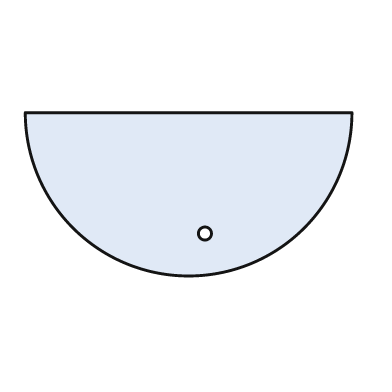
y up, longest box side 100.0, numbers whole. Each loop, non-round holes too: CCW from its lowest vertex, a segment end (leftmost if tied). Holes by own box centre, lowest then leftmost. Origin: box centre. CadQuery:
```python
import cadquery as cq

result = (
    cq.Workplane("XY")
    .moveTo(-50.0, 25.0)
    .threePointArc((0.0, -25.0), (50.0, 25.0))
    .close()
    .moveTo(5.0, -12.0)
    .circle(2.0)
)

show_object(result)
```